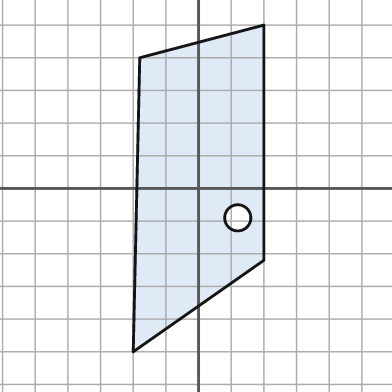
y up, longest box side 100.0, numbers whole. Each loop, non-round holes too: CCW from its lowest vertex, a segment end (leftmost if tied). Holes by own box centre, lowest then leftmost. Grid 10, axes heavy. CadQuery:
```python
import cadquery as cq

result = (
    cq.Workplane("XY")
    .moveTo(-20.0, -50.0)
    .lineTo(20.0, -22.0)
    .lineTo(20.0, 50.0)
    .lineTo(-18.0, 40.0)
    .close()
    .moveTo(12.0, -9.0)
    .circle(4.0)
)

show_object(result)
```